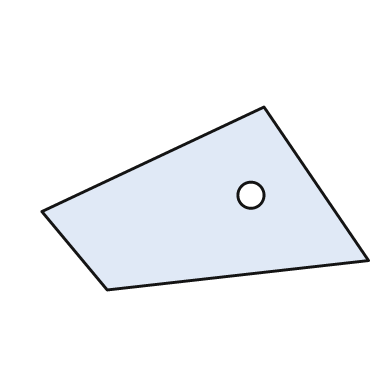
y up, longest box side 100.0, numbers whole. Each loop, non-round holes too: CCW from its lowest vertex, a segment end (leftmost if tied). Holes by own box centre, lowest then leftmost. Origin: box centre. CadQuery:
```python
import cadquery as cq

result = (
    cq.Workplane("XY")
    .moveTo(-30.0, -28.0)
    .lineTo(50.0, -19.0)
    .lineTo(18.0, 28.0)
    .lineTo(-50.0, -4.0)
    .close()
    .moveTo(14.0, 1.0)
    .circle(4.0)
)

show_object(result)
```